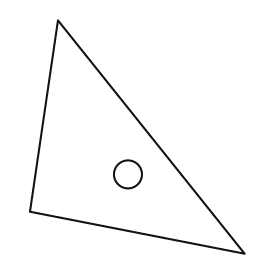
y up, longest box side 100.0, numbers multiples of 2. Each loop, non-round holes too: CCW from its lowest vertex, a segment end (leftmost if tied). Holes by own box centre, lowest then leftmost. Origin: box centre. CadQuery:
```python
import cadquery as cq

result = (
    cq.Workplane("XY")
    .moveTo(46.0, -50.0)
    .lineTo(-34.0, 50.0)
    .lineTo(-46.0, -32.0)
    .close()
    .moveTo(-4.0, -16.0)
    .circle(6.0)
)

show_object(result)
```